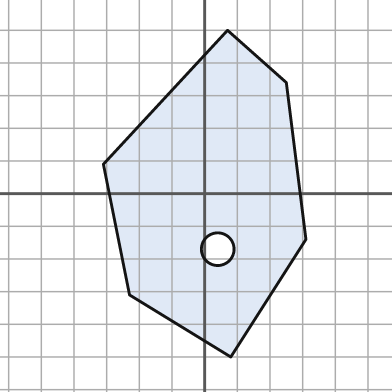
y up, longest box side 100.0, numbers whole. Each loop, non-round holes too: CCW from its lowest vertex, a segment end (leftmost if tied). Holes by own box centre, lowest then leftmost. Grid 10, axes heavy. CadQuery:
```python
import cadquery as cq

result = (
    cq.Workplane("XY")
    .moveTo(8.0, -50.0)
    .lineTo(31.0, -14.0)
    .lineTo(25.0, 34.0)
    .lineTo(7.0, 50.0)
    .lineTo(-31.0, 9.0)
    .lineTo(-23.0, -31.0)
    .close()
    .moveTo(4.0, -17.0)
    .circle(5.0)
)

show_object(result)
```